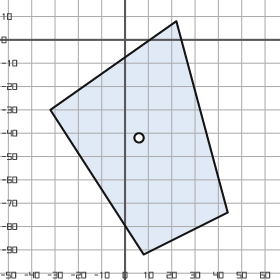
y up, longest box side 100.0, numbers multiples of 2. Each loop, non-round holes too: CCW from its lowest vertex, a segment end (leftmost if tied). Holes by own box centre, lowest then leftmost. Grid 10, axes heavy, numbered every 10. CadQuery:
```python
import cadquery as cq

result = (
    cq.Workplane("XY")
    .moveTo(8.0, -92.0)
    .lineTo(44.0, -74.0)
    .lineTo(22.0, 8.0)
    .lineTo(-32.0, -30.0)
    .close()
    .moveTo(6.0, -42.0)
    .circle(2.0)
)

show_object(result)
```